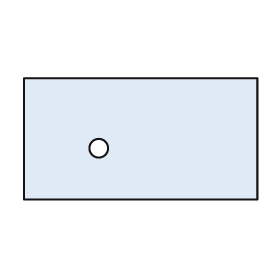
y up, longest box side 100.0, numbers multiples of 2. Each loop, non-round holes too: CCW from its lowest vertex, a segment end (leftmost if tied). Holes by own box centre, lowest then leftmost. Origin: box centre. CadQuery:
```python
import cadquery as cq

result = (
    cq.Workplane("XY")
    .moveTo(-50.0, -26.0)
    .lineTo(50.0, -26.0)
    .lineTo(50.0, 26.0)
    .lineTo(-50.0, 26.0)
    .close()
    .moveTo(-18.0, -4.0)
    .circle(4.0)
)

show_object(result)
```